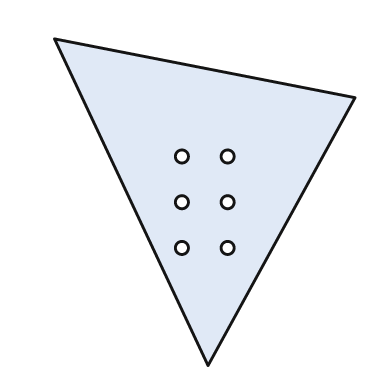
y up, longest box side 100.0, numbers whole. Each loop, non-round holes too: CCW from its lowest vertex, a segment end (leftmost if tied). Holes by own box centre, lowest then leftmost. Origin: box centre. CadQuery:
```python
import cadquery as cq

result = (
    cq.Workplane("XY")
    .moveTo(1.0, -50.0)
    .lineTo(46.0, 32.0)
    .lineTo(-46.0, 50.0)
    .close()
    .moveTo(-7.0, -14.0)
    .circle(2.0)
    .moveTo(7.0, -14.0)
    .circle(2.0)
    .moveTo(-7.0, 0.0)
    .circle(2.0)
    .moveTo(7.0, 0.0)
    .circle(2.0)
    .moveTo(-7.0, 14.0)
    .circle(2.0)
    .moveTo(7.0, 14.0)
    .circle(2.0)
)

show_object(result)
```